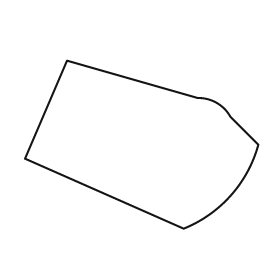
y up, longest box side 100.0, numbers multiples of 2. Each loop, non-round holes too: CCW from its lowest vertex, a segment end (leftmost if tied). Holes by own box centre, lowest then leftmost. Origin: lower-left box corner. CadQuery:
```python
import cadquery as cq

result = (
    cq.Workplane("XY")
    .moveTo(68.0, 0.0)
    .threePointArc((88.0, 14.0), (100.0, 36.0))
    .lineTo(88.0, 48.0)
    .threePointArc((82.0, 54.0), (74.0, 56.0))
    .lineTo(18.0, 72.0)
    .lineTo(0.0, 30.0)
    .close()
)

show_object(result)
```